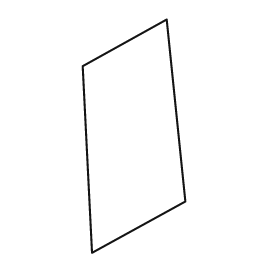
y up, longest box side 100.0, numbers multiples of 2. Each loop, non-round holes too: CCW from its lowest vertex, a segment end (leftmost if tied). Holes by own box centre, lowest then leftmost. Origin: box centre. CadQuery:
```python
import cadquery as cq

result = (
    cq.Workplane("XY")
    .moveTo(-18.0, -50.0)
    .lineTo(22.0, -28.0)
    .lineTo(14.0, 50.0)
    .lineTo(-22.0, 30.0)
    .close()
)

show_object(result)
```